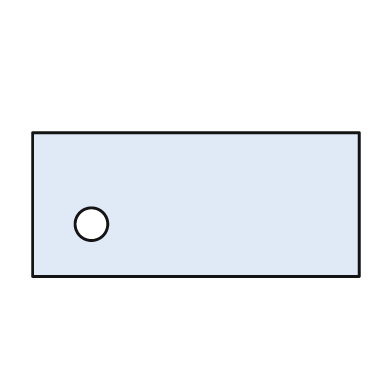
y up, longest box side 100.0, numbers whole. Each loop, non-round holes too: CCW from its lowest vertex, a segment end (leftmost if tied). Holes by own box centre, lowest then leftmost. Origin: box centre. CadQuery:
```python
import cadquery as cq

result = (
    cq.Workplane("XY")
    .moveTo(-50.0, -22.0)
    .lineTo(50.0, -22.0)
    .lineTo(50.0, 22.0)
    .lineTo(-50.0, 22.0)
    .close()
    .moveTo(-32.0, -6.0)
    .circle(5.0)
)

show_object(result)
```